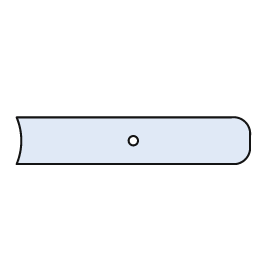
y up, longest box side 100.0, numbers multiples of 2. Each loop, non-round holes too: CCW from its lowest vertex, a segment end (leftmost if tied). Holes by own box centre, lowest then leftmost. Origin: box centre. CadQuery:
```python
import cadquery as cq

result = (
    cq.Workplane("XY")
    .moveTo(-50.0, -10.0)
    .lineTo(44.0, -10.0)
    .threePointArc((48.0, -8.0), (50.0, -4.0))
    .lineTo(50.0, 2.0)
    .threePointArc((48.0, 8.0), (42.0, 10.0))
    .lineTo(-50.0, 10.0)
    .threePointArc((-48.0, 0.0), (-50.0, -10.0))
    .close()
    .moveTo(0.0, 0.0)
    .circle(2.0)
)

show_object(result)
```